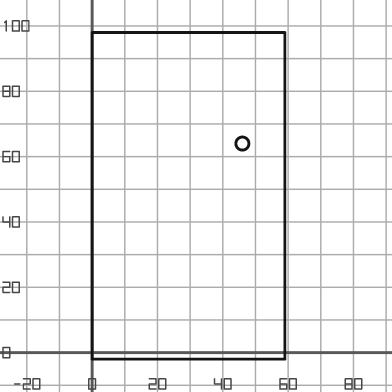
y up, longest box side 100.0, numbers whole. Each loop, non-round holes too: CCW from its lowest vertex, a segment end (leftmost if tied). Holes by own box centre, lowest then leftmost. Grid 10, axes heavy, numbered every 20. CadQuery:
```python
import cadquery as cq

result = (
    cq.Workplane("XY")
    .moveTo(0.0, -2.0)
    .lineTo(59.0, -2.0)
    .lineTo(59.0, 98.0)
    .lineTo(0.0, 98.0)
    .close()
    .moveTo(46.0, 64.0)
    .circle(2.0)
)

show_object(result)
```